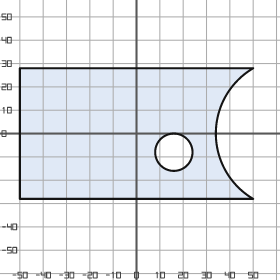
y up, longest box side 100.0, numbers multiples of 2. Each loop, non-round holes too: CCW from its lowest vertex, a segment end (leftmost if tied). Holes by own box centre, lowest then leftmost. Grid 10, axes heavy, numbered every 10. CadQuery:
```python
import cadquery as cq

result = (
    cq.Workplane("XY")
    .moveTo(-50.0, -28.0)
    .lineTo(50.0, -28.0)
    .threePointArc((34.0, 0.0), (50.0, 28.0))
    .lineTo(-50.0, 28.0)
    .close()
    .moveTo(16.0, -8.0)
    .circle(8.0)
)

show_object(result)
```